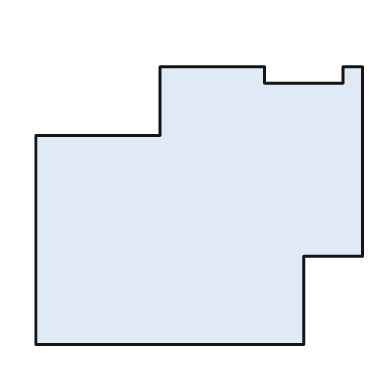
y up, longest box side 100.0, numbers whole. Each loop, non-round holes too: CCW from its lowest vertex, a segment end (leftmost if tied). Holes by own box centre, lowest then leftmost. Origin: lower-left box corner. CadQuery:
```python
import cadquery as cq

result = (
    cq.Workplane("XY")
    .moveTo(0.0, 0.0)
    .lineTo(82.0, 0.0)
    .lineTo(82.0, 27.0)
    .lineTo(100.0, 27.0)
    .lineTo(100.0, 85.0)
    .lineTo(94.0, 85.0)
    .lineTo(94.0, 80.0)
    .lineTo(70.0, 80.0)
    .lineTo(70.0, 85.0)
    .lineTo(38.0, 85.0)
    .lineTo(38.0, 64.0)
    .lineTo(0.0, 64.0)
    .close()
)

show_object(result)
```